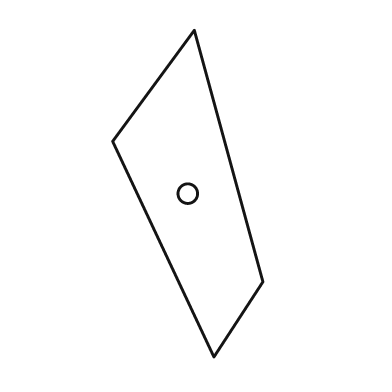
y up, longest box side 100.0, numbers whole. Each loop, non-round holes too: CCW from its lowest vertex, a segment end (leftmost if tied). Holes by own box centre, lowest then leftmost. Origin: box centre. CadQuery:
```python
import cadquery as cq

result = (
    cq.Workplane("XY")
    .moveTo(8.0, -50.0)
    .lineTo(23.0, -27.0)
    .lineTo(2.0, 50.0)
    .lineTo(-23.0, 16.0)
    .close()
    .moveTo(0.0, 0.0)
    .circle(3.0)
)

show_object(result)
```